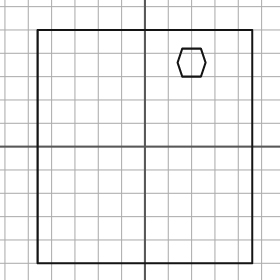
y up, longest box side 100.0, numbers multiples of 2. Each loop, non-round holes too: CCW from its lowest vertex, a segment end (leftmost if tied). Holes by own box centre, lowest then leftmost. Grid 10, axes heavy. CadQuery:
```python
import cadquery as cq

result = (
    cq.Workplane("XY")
    .moveTo(-46.0, -50.0)
    .lineTo(46.0, -50.0)
    .lineTo(46.0, 50.0)
    .lineTo(-46.0, 50.0)
    .close()
    .moveTo(16.0, 30.0)
    .lineTo(24.0, 30.0)
    .lineTo(26.0, 36.0)
    .lineTo(24.0, 42.0)
    .lineTo(16.0, 42.0)
    .lineTo(14.0, 36.0)
    .close()
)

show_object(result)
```